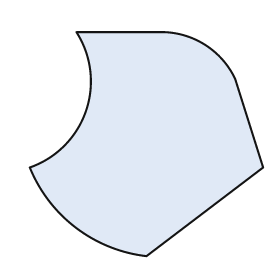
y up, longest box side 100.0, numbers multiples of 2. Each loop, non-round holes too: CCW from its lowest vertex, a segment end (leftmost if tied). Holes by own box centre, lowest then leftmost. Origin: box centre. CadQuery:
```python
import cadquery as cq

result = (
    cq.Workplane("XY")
    .moveTo(0.0, -48.0)
    .lineTo(50.0, -10.0)
    .lineTo(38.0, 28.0)
    .threePointArc((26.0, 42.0), (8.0, 48.0))
    .lineTo(-30.0, 48.0)
    .threePointArc((-26.0, 14.0), (-50.0, -10.0))
    .threePointArc((-30.0, -36.0), (0.0, -48.0))
    .close()
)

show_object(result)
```